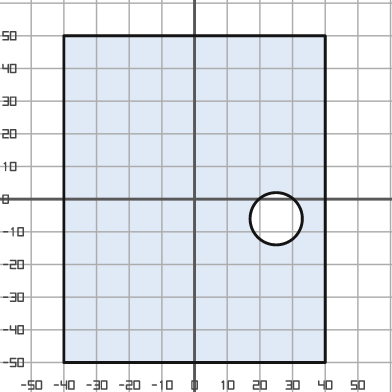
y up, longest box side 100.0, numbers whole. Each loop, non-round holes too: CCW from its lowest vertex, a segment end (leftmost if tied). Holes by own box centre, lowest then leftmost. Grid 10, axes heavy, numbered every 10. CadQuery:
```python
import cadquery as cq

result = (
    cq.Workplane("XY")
    .moveTo(-40.0, -50.0)
    .lineTo(40.0, -50.0)
    .lineTo(40.0, 50.0)
    .lineTo(-40.0, 50.0)
    .close()
    .moveTo(25.0, -6.0)
    .circle(8.0)
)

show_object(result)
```